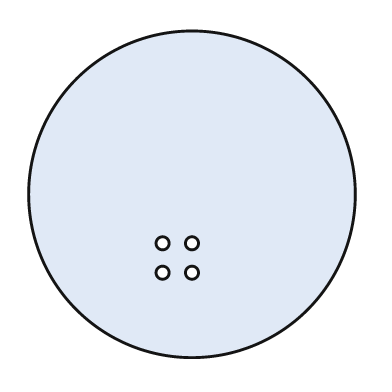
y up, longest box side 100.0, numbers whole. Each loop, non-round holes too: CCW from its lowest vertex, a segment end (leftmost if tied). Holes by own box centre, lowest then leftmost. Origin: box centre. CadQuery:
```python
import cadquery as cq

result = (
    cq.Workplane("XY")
    .moveTo(0.0, 0.0)
    .circle(50.0)
    .moveTo(-9.0, -24.0)
    .circle(2.0)
    .moveTo(0.0, -24.0)
    .circle(2.0)
    .moveTo(-9.0, -15.0)
    .circle(2.0)
    .moveTo(0.0, -15.0)
    .circle(2.0)
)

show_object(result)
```